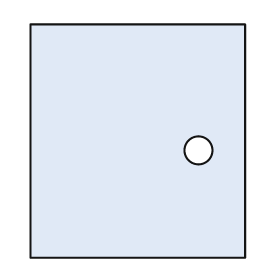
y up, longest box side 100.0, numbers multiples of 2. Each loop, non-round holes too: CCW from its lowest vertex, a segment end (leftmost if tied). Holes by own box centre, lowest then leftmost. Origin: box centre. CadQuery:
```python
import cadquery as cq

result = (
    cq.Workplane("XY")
    .moveTo(-46.0, -50.0)
    .lineTo(46.0, -50.0)
    .lineTo(46.0, 50.0)
    .lineTo(-46.0, 50.0)
    .close()
    .moveTo(26.0, -4.0)
    .circle(6.0)
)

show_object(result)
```